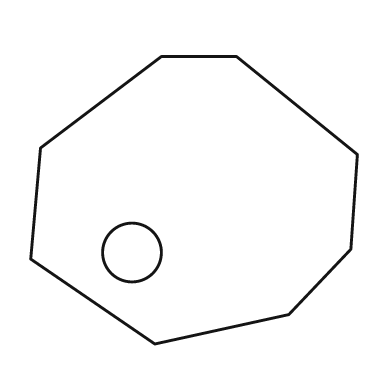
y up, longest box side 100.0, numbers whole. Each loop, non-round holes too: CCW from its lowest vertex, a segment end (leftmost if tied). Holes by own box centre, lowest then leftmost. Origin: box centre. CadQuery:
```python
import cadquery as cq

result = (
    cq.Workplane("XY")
    .moveTo(-12.0, -44.0)
    .lineTo(29.0, -35.0)
    .lineTo(48.0, -15.0)
    .lineTo(50.0, 14.0)
    .lineTo(13.0, 44.0)
    .lineTo(-10.0, 44.0)
    .lineTo(-47.0, 16.0)
    .lineTo(-50.0, -18.0)
    .close()
    .moveTo(-19.0, -16.0)
    .circle(9.0)
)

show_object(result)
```